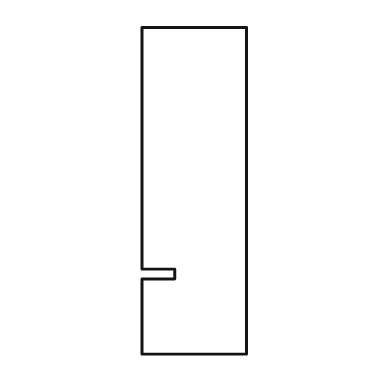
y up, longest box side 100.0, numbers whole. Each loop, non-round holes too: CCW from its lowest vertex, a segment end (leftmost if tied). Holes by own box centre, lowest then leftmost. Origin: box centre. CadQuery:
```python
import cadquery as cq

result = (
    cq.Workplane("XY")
    .moveTo(-16.0, -50.0)
    .lineTo(16.0, -50.0)
    .lineTo(16.0, 50.0)
    .lineTo(-16.0, 50.0)
    .lineTo(-16.0, -24.0)
    .lineTo(-6.0, -24.0)
    .lineTo(-6.0, -27.0)
    .lineTo(-16.0, -27.0)
    .close()
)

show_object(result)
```